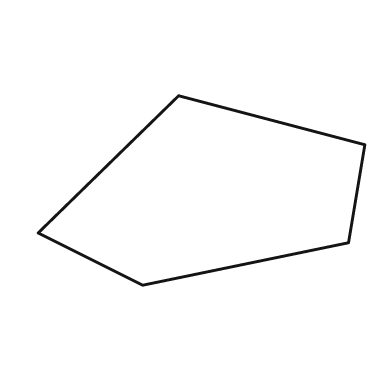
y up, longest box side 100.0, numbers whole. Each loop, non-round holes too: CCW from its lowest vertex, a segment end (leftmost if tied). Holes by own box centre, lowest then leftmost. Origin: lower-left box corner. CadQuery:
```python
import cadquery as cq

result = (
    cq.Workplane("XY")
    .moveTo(32.0, 0.0)
    .lineTo(95.0, 13.0)
    .lineTo(100.0, 43.0)
    .lineTo(43.0, 58.0)
    .lineTo(0.0, 16.0)
    .close()
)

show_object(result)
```